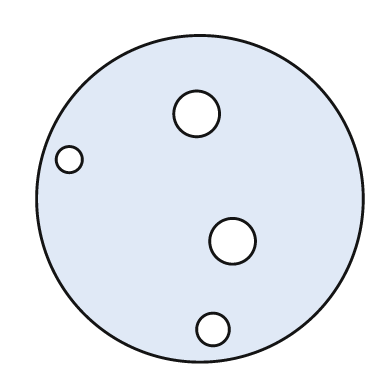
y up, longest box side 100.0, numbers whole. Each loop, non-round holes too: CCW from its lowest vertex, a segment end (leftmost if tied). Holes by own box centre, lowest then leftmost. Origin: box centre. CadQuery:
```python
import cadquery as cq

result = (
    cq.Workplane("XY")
    .moveTo(0.0, 0.0)
    .circle(50.0)
    .moveTo(4.0, -40.0)
    .circle(5.0)
    .moveTo(10.0, -13.0)
    .circle(7.0)
    .moveTo(-40.0, 12.0)
    .circle(4.0)
    .moveTo(-1.0, 26.0)
    .circle(7.0)
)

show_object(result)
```